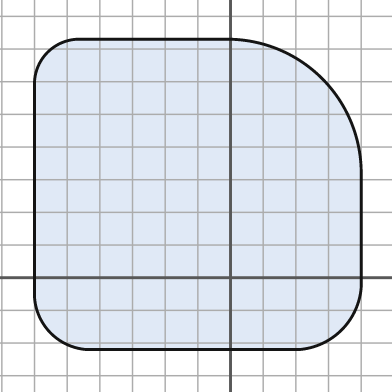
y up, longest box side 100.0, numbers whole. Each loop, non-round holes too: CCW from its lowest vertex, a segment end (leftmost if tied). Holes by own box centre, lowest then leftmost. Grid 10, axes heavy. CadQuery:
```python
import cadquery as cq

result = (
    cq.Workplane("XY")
    .moveTo(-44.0, -22.0)
    .lineTo(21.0, -22.0)
    .threePointArc((34.0, -16.0), (40.0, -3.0))
    .lineTo(40.0, 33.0)
    .threePointArc((28.0, 61.0), (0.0, 73.0))
    .lineTo(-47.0, 73.0)
    .threePointArc((-56.0, 69.0), (-60.0, 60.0))
    .lineTo(-60.0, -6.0)
    .threePointArc((-55.0, -17.0), (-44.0, -22.0))
    .close()
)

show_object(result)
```